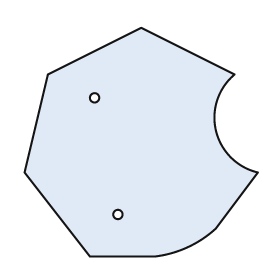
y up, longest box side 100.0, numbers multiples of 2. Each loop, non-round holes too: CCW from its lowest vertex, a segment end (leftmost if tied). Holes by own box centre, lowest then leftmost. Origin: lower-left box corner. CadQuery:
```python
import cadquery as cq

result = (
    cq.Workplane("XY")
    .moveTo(28.0, 0.0)
    .lineTo(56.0, 0.0)
    .threePointArc((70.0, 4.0), (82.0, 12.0))
    .lineTo(100.0, 36.0)
    .threePointArc((82.0, 54.0), (90.0, 78.0))
    .lineTo(50.0, 98.0)
    .lineTo(10.0, 78.0)
    .lineTo(0.0, 36.0)
    .close()
    .moveTo(40.0, 18.0)
    .circle(2.0)
    .moveTo(30.0, 68.0)
    .circle(2.0)
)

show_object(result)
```